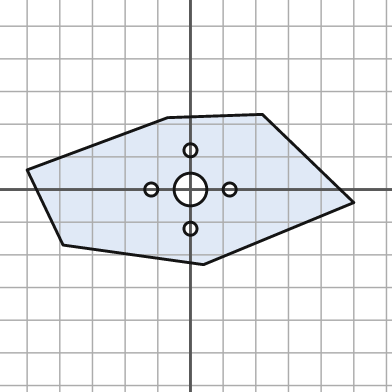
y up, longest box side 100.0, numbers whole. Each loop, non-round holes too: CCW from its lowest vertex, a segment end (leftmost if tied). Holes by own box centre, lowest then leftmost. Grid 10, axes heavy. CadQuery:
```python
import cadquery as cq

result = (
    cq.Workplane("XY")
    .moveTo(4.0, -23.0)
    .lineTo(50.0, -4.0)
    .lineTo(22.0, 23.0)
    .lineTo(-7.0, 22.0)
    .lineTo(-50.0, 6.0)
    .lineTo(-39.0, -17.0)
    .close()
    .moveTo(0.0, -12.0)
    .circle(2.0)
    .moveTo(-12.0, 0.0)
    .circle(2.0)
    .moveTo(0.0, 0.0)
    .circle(5.0)
    .moveTo(12.0, 0.0)
    .circle(2.0)
    .moveTo(0.0, 12.0)
    .circle(2.0)
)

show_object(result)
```